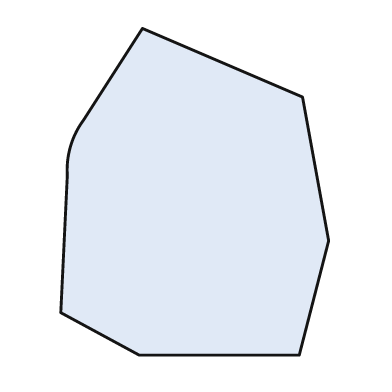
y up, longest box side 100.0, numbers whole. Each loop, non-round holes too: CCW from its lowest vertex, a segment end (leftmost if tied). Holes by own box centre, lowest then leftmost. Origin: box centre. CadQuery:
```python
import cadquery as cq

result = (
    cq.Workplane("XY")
    .moveTo(-17.0, -50.0)
    .lineTo(32.0, -50.0)
    .lineTo(41.0, -15.0)
    .lineTo(33.0, 29.0)
    .lineTo(-16.0, 50.0)
    .lineTo(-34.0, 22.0)
    .threePointArc((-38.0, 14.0), (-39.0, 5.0))
    .lineTo(-41.0, -37.0)
    .close()
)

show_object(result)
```